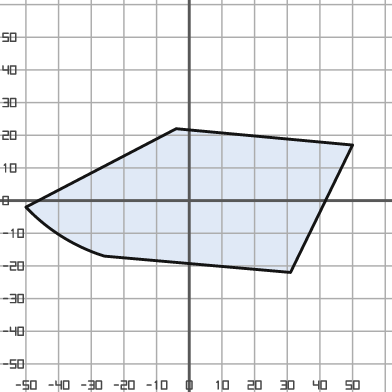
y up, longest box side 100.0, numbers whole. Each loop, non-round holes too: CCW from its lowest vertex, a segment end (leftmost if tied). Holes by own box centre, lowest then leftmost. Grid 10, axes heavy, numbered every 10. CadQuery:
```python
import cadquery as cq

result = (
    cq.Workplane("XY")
    .moveTo(31.0, -22.0)
    .lineTo(50.0, 17.0)
    .lineTo(-4.0, 22.0)
    .lineTo(-50.0, -2.0)
    .threePointArc((-39.0, -11.0), (-26.0, -17.0))
    .close()
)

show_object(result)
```